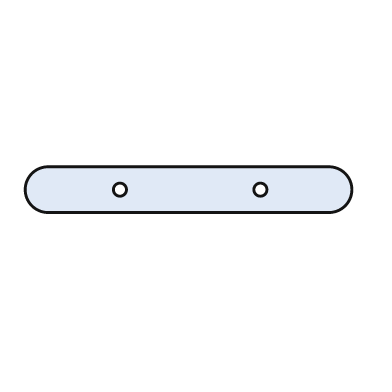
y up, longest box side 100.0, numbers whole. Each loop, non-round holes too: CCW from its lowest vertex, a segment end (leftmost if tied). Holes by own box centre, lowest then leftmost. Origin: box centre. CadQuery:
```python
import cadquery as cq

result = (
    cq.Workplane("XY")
    .moveTo(-43.0, -7.0)
    .lineTo(43.0, -7.0)
    .threePointArc((50.0, 0.0), (43.0, 7.0))
    .lineTo(-43.0, 7.0)
    .threePointArc((-50.0, 0.0), (-43.0, -7.0))
    .close()
    .moveTo(-21.0, 0.0)
    .circle(2.0)
    .moveTo(22.0, 0.0)
    .circle(2.0)
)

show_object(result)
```